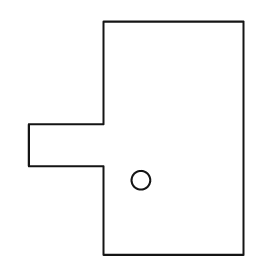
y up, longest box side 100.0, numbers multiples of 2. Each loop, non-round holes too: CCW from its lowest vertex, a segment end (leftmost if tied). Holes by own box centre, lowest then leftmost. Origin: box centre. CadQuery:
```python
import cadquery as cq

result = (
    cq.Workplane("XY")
    .moveTo(-14.0, -50.0)
    .lineTo(46.0, -50.0)
    .lineTo(46.0, 50.0)
    .lineTo(-14.0, 50.0)
    .lineTo(-14.0, 6.0)
    .lineTo(-46.0, 6.0)
    .lineTo(-46.0, -12.0)
    .lineTo(-14.0, -12.0)
    .close()
    .moveTo(2.0, -18.0)
    .circle(4.0)
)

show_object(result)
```